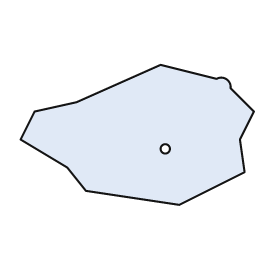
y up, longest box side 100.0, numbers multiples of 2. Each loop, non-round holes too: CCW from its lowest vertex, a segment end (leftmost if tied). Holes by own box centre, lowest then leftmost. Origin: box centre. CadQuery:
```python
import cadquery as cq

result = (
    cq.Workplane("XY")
    .moveTo(18.0, -30.0)
    .lineTo(46.0, -16.0)
    .lineTo(44.0, -2.0)
    .lineTo(50.0, 10.0)
    .lineTo(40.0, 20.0)
    .threePointArc((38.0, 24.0), (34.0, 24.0))
    .lineTo(10.0, 30.0)
    .lineTo(-26.0, 14.0)
    .lineTo(-44.0, 10.0)
    .lineTo(-50.0, -2.0)
    .lineTo(-30.0, -14.0)
    .lineTo(-22.0, -24.0)
    .close()
    .moveTo(12.0, -6.0)
    .circle(2.0)
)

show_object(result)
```